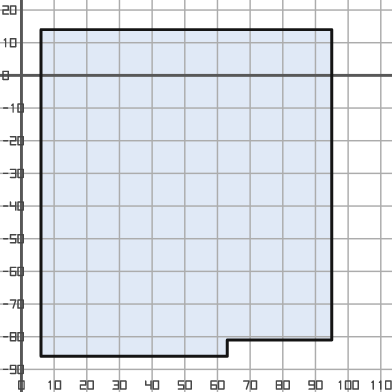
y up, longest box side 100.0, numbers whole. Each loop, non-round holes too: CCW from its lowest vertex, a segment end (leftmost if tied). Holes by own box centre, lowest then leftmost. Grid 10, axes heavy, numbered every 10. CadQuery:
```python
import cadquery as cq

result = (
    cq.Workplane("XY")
    .moveTo(6.0, -86.0)
    .lineTo(63.0, -86.0)
    .lineTo(63.0, -81.0)
    .lineTo(95.0, -81.0)
    .lineTo(95.0, 14.0)
    .lineTo(6.0, 14.0)
    .close()
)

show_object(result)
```